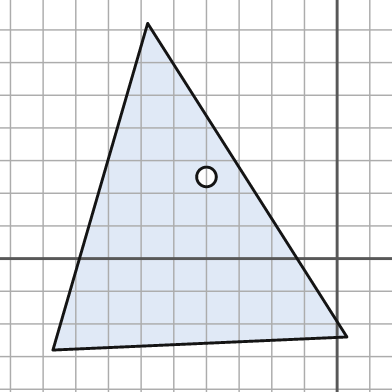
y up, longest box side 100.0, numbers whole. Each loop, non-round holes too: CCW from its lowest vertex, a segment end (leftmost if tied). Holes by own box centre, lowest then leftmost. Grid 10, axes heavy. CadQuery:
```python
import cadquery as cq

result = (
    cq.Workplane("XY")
    .moveTo(-87.0, -28.0)
    .lineTo(3.0, -24.0)
    .lineTo(-58.0, 72.0)
    .close()
    .moveTo(-40.0, 25.0)
    .circle(3.0)
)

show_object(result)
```